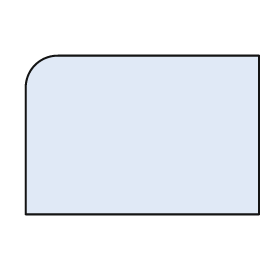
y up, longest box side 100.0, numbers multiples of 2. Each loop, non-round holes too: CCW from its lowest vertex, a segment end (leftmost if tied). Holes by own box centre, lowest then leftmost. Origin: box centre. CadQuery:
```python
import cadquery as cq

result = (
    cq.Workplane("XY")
    .moveTo(-50.0, -34.0)
    .lineTo(50.0, -34.0)
    .lineTo(50.0, 34.0)
    .lineTo(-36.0, 34.0)
    .threePointArc((-46.0, 30.0), (-50.0, 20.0))
    .close()
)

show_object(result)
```